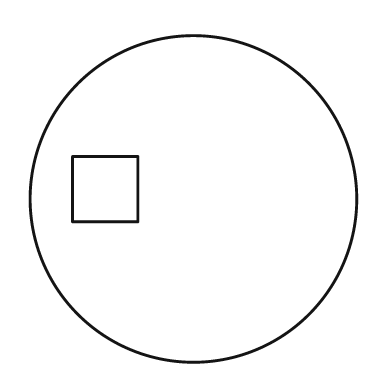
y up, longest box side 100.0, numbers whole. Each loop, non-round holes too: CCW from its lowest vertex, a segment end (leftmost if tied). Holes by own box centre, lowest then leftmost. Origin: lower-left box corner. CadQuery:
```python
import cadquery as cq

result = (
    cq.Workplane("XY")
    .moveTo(50.0, 50.0)
    .circle(50.0)
    .moveTo(13.0, 43.0)
    .lineTo(33.0, 43.0)
    .lineTo(33.0, 63.0)
    .lineTo(13.0, 63.0)
    .close()
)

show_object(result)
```